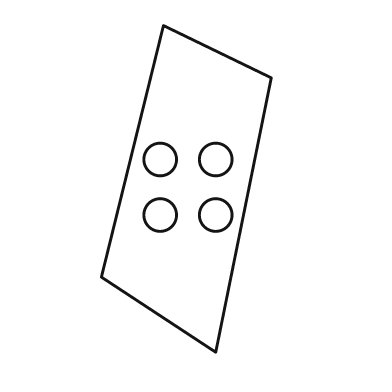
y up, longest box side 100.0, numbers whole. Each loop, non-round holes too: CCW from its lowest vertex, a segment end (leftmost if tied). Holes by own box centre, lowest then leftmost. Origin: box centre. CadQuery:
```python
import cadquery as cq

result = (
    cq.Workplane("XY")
    .moveTo(9.0, -50.0)
    .lineTo(26.0, 34.0)
    .lineTo(-7.0, 50.0)
    .lineTo(-26.0, -27.0)
    .close()
    .moveTo(-8.0, -8.0)
    .circle(5.0)
    .moveTo(9.0, -8.0)
    .circle(5.0)
    .moveTo(-8.0, 9.0)
    .circle(5.0)
    .moveTo(9.0, 9.0)
    .circle(5.0)
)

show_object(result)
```